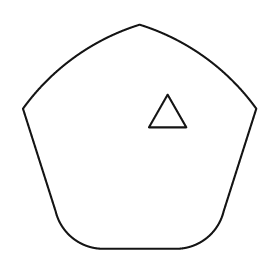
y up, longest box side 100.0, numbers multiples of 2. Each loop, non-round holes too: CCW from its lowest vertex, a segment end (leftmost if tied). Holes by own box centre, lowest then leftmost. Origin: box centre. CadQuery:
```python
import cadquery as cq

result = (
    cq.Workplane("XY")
    .moveTo(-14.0, -48.0)
    .lineTo(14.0, -48.0)
    .threePointArc((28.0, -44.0), (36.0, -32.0))
    .lineTo(50.0, 12.0)
    .threePointArc((28.0, 34.0), (0.0, 48.0))
    .threePointArc((-28.0, 34.0), (-50.0, 12.0))
    .lineTo(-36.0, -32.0)
    .threePointArc((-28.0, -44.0), (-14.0, -48.0))
    .close()
    .moveTo(4.0, 4.0)
    .lineTo(20.0, 4.0)
    .lineTo(12.0, 18.0)
    .close()
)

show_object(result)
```